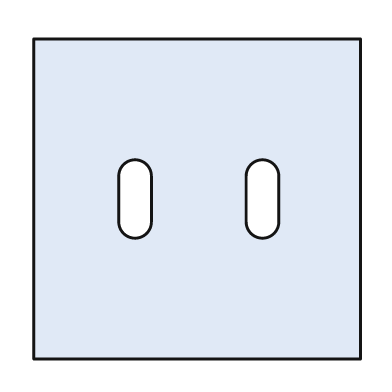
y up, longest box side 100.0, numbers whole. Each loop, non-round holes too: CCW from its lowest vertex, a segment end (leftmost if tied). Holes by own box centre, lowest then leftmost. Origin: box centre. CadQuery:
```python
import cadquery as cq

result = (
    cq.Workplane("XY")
    .moveTo(-50.0, -49.0)
    .lineTo(50.0, -49.0)
    .lineTo(50.0, 49.0)
    .lineTo(-50.0, 49.0)
    .close()
    .moveTo(-24.0, -7.0)
    .threePointArc((-19.0, -12.0), (-14.0, -7.0))
    .lineTo(-14.0, 7.0)
    .threePointArc((-19.0, 12.0), (-24.0, 7.0))
    .close()
    .moveTo(15.0, -7.0)
    .threePointArc((20.0, -12.0), (25.0, -7.0))
    .lineTo(25.0, 7.0)
    .threePointArc((20.0, 12.0), (15.0, 7.0))
    .close()
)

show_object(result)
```